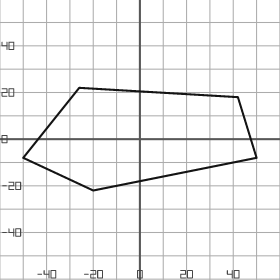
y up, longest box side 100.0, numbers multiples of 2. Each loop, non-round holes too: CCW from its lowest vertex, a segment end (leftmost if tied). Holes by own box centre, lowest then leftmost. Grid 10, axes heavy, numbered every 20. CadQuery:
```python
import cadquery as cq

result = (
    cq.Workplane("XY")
    .moveTo(-20.0, -22.0)
    .lineTo(50.0, -8.0)
    .lineTo(42.0, 18.0)
    .lineTo(-26.0, 22.0)
    .lineTo(-50.0, -8.0)
    .close()
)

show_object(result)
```